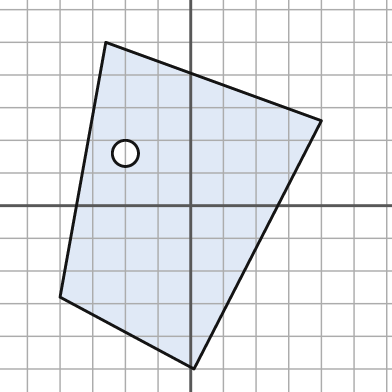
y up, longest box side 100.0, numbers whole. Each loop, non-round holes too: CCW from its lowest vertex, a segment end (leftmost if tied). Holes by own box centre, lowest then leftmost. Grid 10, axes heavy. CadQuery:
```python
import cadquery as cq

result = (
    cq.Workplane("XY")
    .moveTo(1.0, -50.0)
    .lineTo(40.0, 26.0)
    .lineTo(-26.0, 50.0)
    .lineTo(-40.0, -28.0)
    .close()
    .moveTo(-20.0, 16.0)
    .circle(4.0)
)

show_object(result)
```